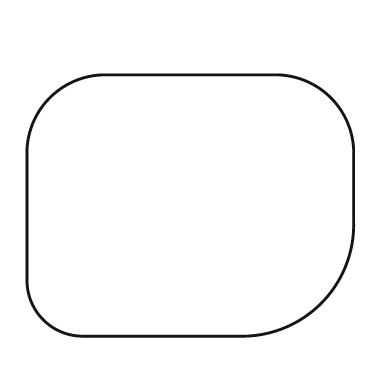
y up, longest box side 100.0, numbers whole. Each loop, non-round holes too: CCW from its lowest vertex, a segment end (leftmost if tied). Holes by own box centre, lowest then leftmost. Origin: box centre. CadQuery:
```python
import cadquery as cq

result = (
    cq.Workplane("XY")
    .moveTo(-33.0, -40.0)
    .lineTo(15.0, -40.0)
    .threePointArc((40.0, -30.0), (50.0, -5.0))
    .lineTo(50.0, 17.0)
    .threePointArc((43.0, 33.0), (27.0, 40.0))
    .lineTo(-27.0, 40.0)
    .threePointArc((-43.0, 33.0), (-50.0, 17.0))
    .lineTo(-50.0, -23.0)
    .threePointArc((-45.0, -35.0), (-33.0, -40.0))
    .close()
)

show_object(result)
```